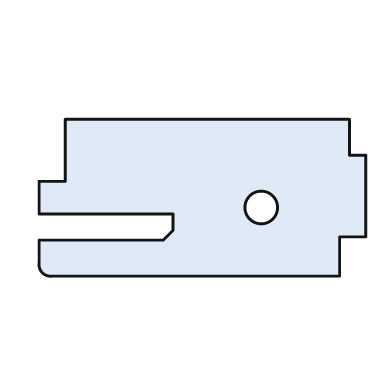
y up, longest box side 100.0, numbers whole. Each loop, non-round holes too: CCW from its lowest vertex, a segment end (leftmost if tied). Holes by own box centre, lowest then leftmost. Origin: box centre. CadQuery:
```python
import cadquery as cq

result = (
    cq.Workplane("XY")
    .moveTo(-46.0, -24.0)
    .lineTo(42.0, -24.0)
    .lineTo(42.0, -12.0)
    .lineTo(50.0, -12.0)
    .lineTo(50.0, 13.0)
    .lineTo(45.0, 13.0)
    .lineTo(45.0, 24.0)
    .lineTo(-42.0, 24.0)
    .lineTo(-42.0, 5.0)
    .lineTo(-50.0, 5.0)
    .lineTo(-50.0, -5.0)
    .lineTo(-9.0, -5.0)
    .lineTo(-9.0, -10.0)
    .lineTo(-12.0, -13.0)
    .lineTo(-50.0, -13.0)
    .lineTo(-50.0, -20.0)
    .threePointArc((-49.0, -23.0), (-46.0, -24.0))
    .close()
    .moveTo(18.0, -3.0)
    .circle(5.0)
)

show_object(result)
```